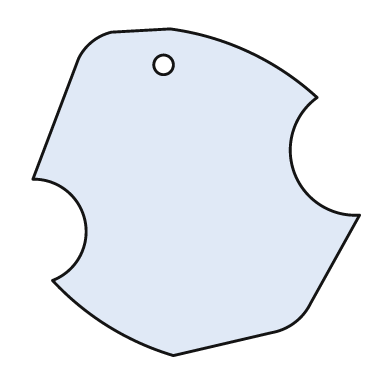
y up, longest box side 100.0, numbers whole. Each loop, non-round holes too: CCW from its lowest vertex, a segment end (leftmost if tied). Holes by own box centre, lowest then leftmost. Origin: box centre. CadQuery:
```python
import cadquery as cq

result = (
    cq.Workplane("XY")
    .moveTo(-7.0, -50.0)
    .lineTo(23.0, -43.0)
    .threePointArc((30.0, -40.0), (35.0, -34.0))
    .lineTo(50.0, -7.0)
    .threePointArc((30.0, 6.0), (37.0, 29.0))
    .threePointArc((16.0, 43.0), (-8.0, 50.0))
    .lineTo(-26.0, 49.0)
    .threePointArc((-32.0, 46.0), (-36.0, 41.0))
    .lineTo(-50.0, 4.0)
    .threePointArc((-34.0, -9.0), (-44.0, -27.0))
    .threePointArc((-27.0, -41.0), (-7.0, -50.0))
    .close()
    .moveTo(-10.0, 39.0)
    .circle(3.0)
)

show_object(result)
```